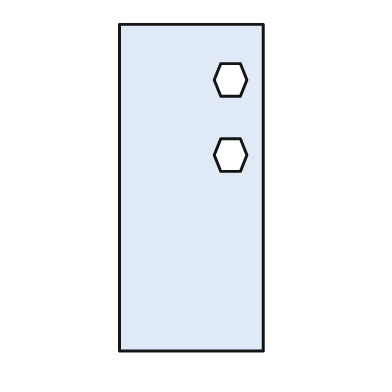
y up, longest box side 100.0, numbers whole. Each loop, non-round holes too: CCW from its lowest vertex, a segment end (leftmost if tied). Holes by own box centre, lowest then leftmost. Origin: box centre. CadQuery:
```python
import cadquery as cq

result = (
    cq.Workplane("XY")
    .moveTo(-22.0, -50.0)
    .lineTo(22.0, -50.0)
    .lineTo(22.0, 50.0)
    .lineTo(-22.0, 50.0)
    .close()
    .moveTo(9.0, 5.0)
    .lineTo(15.0, 5.0)
    .lineTo(17.0, 10.0)
    .lineTo(15.0, 15.0)
    .lineTo(9.0, 15.0)
    .lineTo(7.0, 10.0)
    .close()
    .moveTo(9.0, 28.0)
    .lineTo(15.0, 28.0)
    .lineTo(17.0, 33.0)
    .lineTo(15.0, 38.0)
    .lineTo(9.0, 38.0)
    .lineTo(7.0, 33.0)
    .close()
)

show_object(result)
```